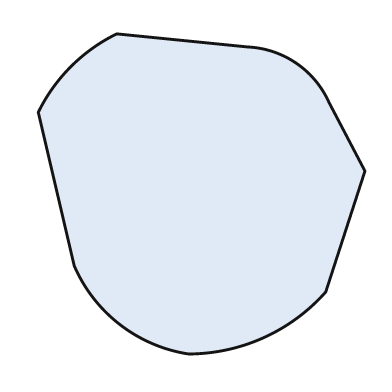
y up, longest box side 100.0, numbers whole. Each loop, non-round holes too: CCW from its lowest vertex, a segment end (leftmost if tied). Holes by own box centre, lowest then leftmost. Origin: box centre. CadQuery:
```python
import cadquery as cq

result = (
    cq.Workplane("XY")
    .moveTo(-4.0, -49.0)
    .threePointArc((19.0, -44.0), (38.0, -30.0))
    .lineTo(50.0, 7.0)
    .lineTo(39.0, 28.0)
    .threePointArc((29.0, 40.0), (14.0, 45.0))
    .lineTo(-26.0, 49.0)
    .threePointArc((-40.0, 39.0), (-50.0, 25.0))
    .lineTo(-39.0, -22.0)
    .threePointArc((-25.0, -40.0), (-4.0, -49.0))
    .close()
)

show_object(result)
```